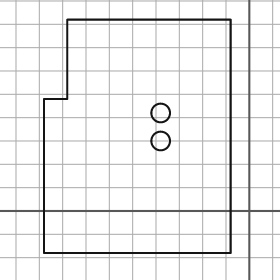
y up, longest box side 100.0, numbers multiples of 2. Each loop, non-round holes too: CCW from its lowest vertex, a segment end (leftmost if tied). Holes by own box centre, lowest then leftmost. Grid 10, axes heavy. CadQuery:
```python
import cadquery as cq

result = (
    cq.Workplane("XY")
    .moveTo(-88.0, -18.0)
    .lineTo(-8.0, -18.0)
    .lineTo(-8.0, 82.0)
    .lineTo(-78.0, 82.0)
    .lineTo(-78.0, 48.0)
    .lineTo(-88.0, 48.0)
    .close()
    .moveTo(-38.0, 30.0)
    .circle(4.0)
    .moveTo(-38.0, 42.0)
    .circle(4.0)
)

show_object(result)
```